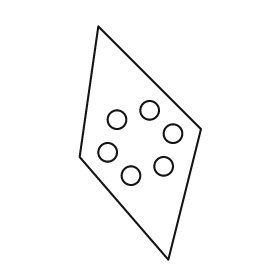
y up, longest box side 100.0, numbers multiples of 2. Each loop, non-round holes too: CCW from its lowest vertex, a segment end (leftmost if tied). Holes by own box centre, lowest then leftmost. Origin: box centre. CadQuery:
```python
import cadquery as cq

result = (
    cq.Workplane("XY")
    .moveTo(12.0, -50.0)
    .lineTo(26.0, 6.0)
    .lineTo(-18.0, 50.0)
    .lineTo(-26.0, -6.0)
    .close()
    .moveTo(-4.0, -14.0)
    .circle(4.0)
    .moveTo(10.0, -10.0)
    .circle(4.0)
    .moveTo(-14.0, -4.0)
    .circle(4.0)
    .moveTo(14.0, 4.0)
    .circle(4.0)
    .moveTo(-10.0, 10.0)
    .circle(4.0)
    .moveTo(4.0, 14.0)
    .circle(4.0)
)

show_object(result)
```